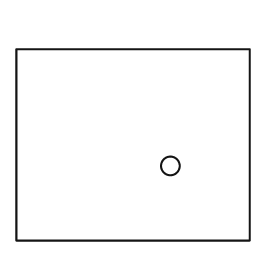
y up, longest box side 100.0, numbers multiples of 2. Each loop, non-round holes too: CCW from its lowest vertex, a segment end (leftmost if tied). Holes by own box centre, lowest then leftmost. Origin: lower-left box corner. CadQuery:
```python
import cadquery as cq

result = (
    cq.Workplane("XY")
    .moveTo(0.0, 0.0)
    .lineTo(100.0, 0.0)
    .lineTo(100.0, 82.0)
    .lineTo(0.0, 82.0)
    .close()
    .moveTo(66.0, 32.0)
    .circle(4.0)
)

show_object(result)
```